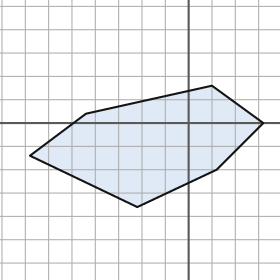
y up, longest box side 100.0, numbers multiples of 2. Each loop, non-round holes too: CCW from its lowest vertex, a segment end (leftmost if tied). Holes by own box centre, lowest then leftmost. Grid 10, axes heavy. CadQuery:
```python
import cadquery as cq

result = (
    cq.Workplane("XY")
    .moveTo(-22.0, -36.0)
    .lineTo(12.0, -20.0)
    .lineTo(32.0, 0.0)
    .lineTo(10.0, 16.0)
    .lineTo(-44.0, 4.0)
    .lineTo(-68.0, -14.0)
    .close()
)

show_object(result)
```